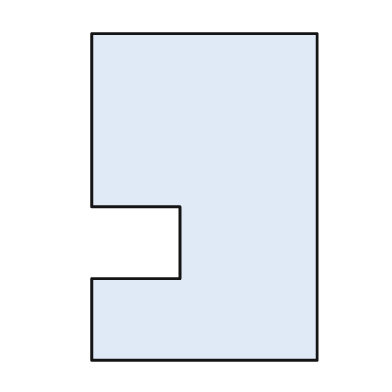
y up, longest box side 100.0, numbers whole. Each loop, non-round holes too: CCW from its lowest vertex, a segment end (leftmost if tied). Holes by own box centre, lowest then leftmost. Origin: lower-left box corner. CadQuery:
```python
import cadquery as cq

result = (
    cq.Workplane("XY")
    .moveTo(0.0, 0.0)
    .lineTo(69.0, 0.0)
    .lineTo(69.0, 100.0)
    .lineTo(0.0, 100.0)
    .lineTo(0.0, 47.0)
    .lineTo(27.0, 47.0)
    .lineTo(27.0, 25.0)
    .lineTo(0.0, 25.0)
    .close()
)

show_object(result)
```